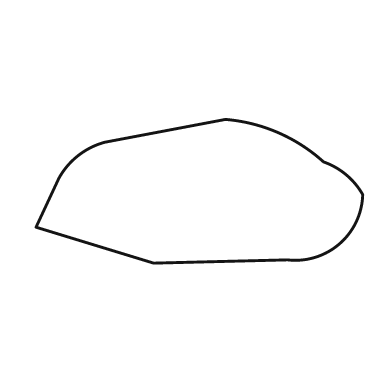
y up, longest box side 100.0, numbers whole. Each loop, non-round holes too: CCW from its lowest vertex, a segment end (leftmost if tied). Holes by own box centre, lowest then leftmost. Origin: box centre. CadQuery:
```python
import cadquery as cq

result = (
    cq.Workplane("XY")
    .moveTo(-14.0, -22.0)
    .lineTo(27.0, -21.0)
    .threePointArc((43.0, -16.0), (50.0, -1.0))
    .threePointArc((45.0, 5.0), (38.0, 9.0))
    .threePointArc((24.0, 18.0), (8.0, 22.0))
    .lineTo(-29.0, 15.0)
    .threePointArc((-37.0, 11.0), (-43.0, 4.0))
    .lineTo(-50.0, -11.0)
    .close()
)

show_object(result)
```